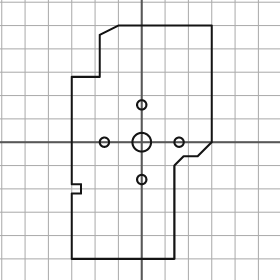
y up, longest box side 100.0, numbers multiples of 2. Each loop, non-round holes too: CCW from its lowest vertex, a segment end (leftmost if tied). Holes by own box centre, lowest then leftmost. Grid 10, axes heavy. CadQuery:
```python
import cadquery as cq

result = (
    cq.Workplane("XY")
    .moveTo(-30.0, -50.0)
    .lineTo(14.0, -50.0)
    .lineTo(14.0, -10.0)
    .lineTo(18.0, -6.0)
    .lineTo(24.0, -6.0)
    .lineTo(30.0, 0.0)
    .lineTo(30.0, 50.0)
    .lineTo(-10.0, 50.0)
    .lineTo(-18.0, 46.0)
    .lineTo(-18.0, 28.0)
    .lineTo(-30.0, 28.0)
    .lineTo(-30.0, -18.0)
    .lineTo(-26.0, -18.0)
    .lineTo(-26.0, -22.0)
    .lineTo(-30.0, -22.0)
    .close()
    .moveTo(0.0, -16.0)
    .circle(2.0)
    .moveTo(-16.0, 0.0)
    .circle(2.0)
    .moveTo(0.0, 0.0)
    .circle(4.0)
    .moveTo(16.0, 0.0)
    .circle(2.0)
    .moveTo(0.0, 16.0)
    .circle(2.0)
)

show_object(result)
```